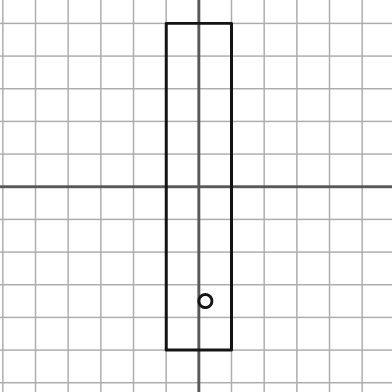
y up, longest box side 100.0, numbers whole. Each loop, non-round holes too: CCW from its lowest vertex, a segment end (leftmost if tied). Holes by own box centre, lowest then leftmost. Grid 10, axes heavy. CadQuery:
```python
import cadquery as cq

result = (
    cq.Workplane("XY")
    .moveTo(-10.0, -50.0)
    .lineTo(10.0, -50.0)
    .lineTo(10.0, 50.0)
    .lineTo(-10.0, 50.0)
    .close()
    .moveTo(2.0, -35.0)
    .circle(2.0)
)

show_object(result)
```